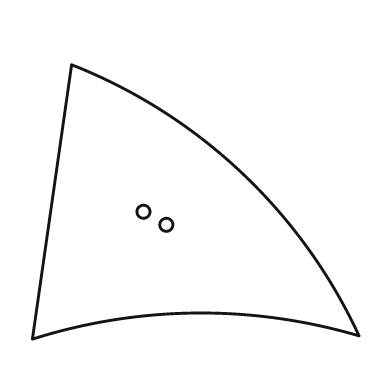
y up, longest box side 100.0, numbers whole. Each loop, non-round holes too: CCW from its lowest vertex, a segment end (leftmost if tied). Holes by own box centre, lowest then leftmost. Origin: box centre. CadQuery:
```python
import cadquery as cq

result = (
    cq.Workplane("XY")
    .moveTo(-50.0, -42.0)
    .threePointArc((0.0, -34.0), (50.0, -41.0))
    .threePointArc((14.0, 9.0), (-38.0, 42.0))
    .close()
    .moveTo(-9.0, -7.0)
    .circle(2.0)
    .moveTo(-16.0, -3.0)
    .circle(2.0)
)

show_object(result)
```